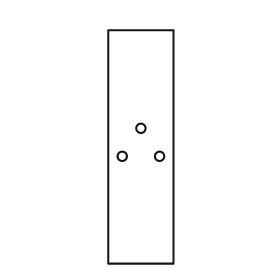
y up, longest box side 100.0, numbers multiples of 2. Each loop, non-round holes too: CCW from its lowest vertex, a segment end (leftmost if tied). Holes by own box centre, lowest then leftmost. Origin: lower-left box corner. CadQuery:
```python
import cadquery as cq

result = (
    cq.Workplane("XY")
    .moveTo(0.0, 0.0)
    .lineTo(28.0, 0.0)
    .lineTo(28.0, 100.0)
    .lineTo(0.0, 100.0)
    .close()
    .moveTo(6.0, 46.0)
    .circle(2.0)
    .moveTo(22.0, 46.0)
    .circle(2.0)
    .moveTo(14.0, 58.0)
    .circle(2.0)
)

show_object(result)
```